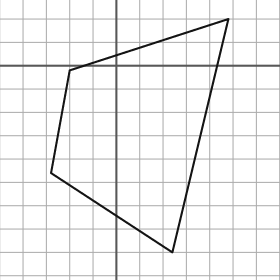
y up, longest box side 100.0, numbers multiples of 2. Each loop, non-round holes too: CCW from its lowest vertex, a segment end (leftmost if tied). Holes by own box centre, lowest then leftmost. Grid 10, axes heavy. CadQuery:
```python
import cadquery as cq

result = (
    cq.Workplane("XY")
    .moveTo(24.0, -80.0)
    .lineTo(48.0, 20.0)
    .lineTo(-20.0, -2.0)
    .lineTo(-28.0, -46.0)
    .close()
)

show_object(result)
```